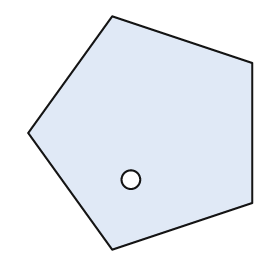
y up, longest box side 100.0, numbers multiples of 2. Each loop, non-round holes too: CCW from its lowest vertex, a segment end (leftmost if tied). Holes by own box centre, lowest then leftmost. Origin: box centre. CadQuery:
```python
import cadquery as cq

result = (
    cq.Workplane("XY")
    .moveTo(-12.0, -50.0)
    .lineTo(48.0, -30.0)
    .lineTo(48.0, 30.0)
    .lineTo(-12.0, 50.0)
    .lineTo(-48.0, 0.0)
    .close()
    .moveTo(-4.0, -20.0)
    .circle(4.0)
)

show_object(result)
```